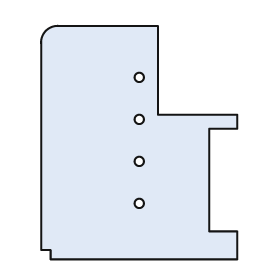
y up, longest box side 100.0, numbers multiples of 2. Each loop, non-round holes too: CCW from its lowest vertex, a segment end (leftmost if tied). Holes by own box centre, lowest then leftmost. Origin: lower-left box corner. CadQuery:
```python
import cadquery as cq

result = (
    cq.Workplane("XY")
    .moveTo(4.0, 0.0)
    .lineTo(84.0, 0.0)
    .lineTo(84.0, 12.0)
    .lineTo(72.0, 12.0)
    .lineTo(72.0, 56.0)
    .lineTo(84.0, 56.0)
    .lineTo(84.0, 62.0)
    .lineTo(50.0, 62.0)
    .lineTo(50.0, 100.0)
    .lineTo(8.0, 100.0)
    .threePointArc((2.0, 98.0), (0.0, 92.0))
    .lineTo(0.0, 4.0)
    .lineTo(4.0, 4.0)
    .close()
    .moveTo(42.0, 24.0)
    .circle(2.0)
    .moveTo(42.0, 42.0)
    .circle(2.0)
    .moveTo(42.0, 60.0)
    .circle(2.0)
    .moveTo(42.0, 78.0)
    .circle(2.0)
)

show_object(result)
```